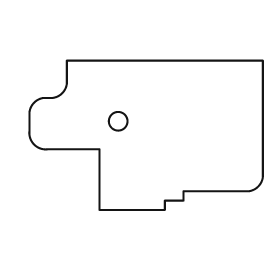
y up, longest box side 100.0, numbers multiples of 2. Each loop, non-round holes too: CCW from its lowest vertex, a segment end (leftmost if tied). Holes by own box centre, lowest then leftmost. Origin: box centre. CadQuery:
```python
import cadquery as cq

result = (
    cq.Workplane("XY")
    .moveTo(-20.0, -32.0)
    .lineTo(8.0, -32.0)
    .lineTo(8.0, -28.0)
    .lineTo(16.0, -28.0)
    .lineTo(16.0, -24.0)
    .lineTo(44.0, -24.0)
    .threePointArc((48.0, -22.0), (50.0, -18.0))
    .lineTo(50.0, 32.0)
    .lineTo(-34.0, 32.0)
    .lineTo(-34.0, 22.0)
    .threePointArc((-36.0, 18.0), (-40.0, 16.0))
    .lineTo(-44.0, 16.0)
    .threePointArc((-48.0, 14.0), (-50.0, 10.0))
    .lineTo(-50.0, 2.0)
    .threePointArc((-48.0, -4.0), (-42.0, -6.0))
    .lineTo(-20.0, -6.0)
    .close()
    .moveTo(-12.0, 6.0)
    .circle(4.0)
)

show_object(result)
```